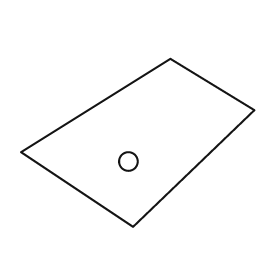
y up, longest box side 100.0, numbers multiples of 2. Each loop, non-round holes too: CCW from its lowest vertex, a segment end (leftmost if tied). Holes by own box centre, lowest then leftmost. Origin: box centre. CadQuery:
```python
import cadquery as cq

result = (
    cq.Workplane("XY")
    .moveTo(-2.0, -36.0)
    .lineTo(50.0, 14.0)
    .lineTo(14.0, 36.0)
    .lineTo(-50.0, -4.0)
    .close()
    .moveTo(-4.0, -8.0)
    .circle(4.0)
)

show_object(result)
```